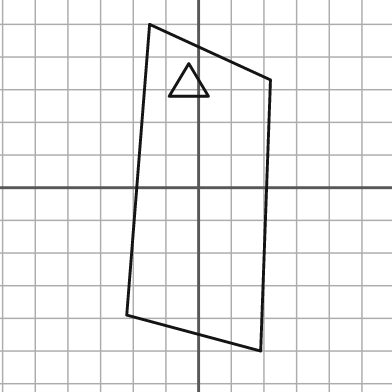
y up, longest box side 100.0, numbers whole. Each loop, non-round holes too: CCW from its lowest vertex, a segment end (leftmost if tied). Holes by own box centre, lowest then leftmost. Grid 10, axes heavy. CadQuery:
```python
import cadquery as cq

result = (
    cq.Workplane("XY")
    .moveTo(19.0, -50.0)
    .lineTo(22.0, 33.0)
    .lineTo(-15.0, 50.0)
    .lineTo(-22.0, -39.0)
    .close()
    .moveTo(-9.0, 28.0)
    .lineTo(3.0, 28.0)
    .lineTo(-3.0, 38.0)
    .close()
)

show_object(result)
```